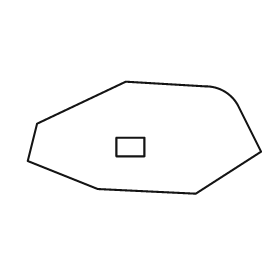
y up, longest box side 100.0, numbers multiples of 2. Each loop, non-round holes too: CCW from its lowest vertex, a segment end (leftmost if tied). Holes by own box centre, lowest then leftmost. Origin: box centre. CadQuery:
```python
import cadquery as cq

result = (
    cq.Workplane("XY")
    .moveTo(22.0, -24.0)
    .lineTo(50.0, -6.0)
    .lineTo(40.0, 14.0)
    .threePointArc((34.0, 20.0), (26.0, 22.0))
    .lineTo(-8.0, 24.0)
    .lineTo(-46.0, 6.0)
    .lineTo(-50.0, -10.0)
    .lineTo(-20.0, -22.0)
    .close()
    .moveTo(-12.0, -8.0)
    .lineTo(0.0, -8.0)
    .lineTo(0.0, 0.0)
    .lineTo(-12.0, 0.0)
    .close()
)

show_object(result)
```